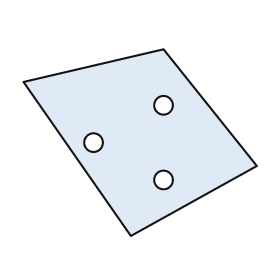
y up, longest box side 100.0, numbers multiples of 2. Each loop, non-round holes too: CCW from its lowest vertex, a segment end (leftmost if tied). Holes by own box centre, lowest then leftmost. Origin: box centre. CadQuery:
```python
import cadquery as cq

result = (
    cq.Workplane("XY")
    .moveTo(-4.0, -40.0)
    .lineTo(50.0, -10.0)
    .lineTo(10.0, 40.0)
    .lineTo(-50.0, 26.0)
    .close()
    .moveTo(10.0, -16.0)
    .circle(4.0)
    .moveTo(-20.0, 0.0)
    .circle(4.0)
    .moveTo(10.0, 16.0)
    .circle(4.0)
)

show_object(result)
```